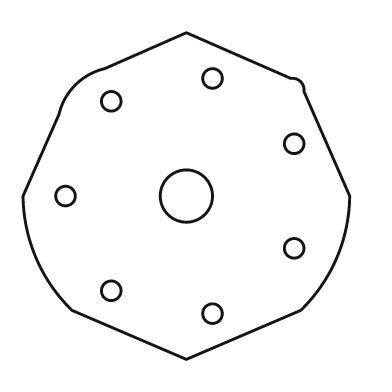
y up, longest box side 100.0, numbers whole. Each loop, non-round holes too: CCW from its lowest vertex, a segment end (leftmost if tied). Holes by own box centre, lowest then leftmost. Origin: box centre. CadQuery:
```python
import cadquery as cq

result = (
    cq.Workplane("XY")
    .moveTo(0.0, -50.0)
    .lineTo(35.0, -35.0)
    .threePointArc((46.0, -19.0), (50.0, 0.0))
    .lineTo(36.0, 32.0)
    .threePointArc((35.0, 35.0), (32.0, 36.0))
    .lineTo(0.0, 50.0)
    .lineTo(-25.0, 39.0)
    .threePointArc((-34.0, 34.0), (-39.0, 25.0))
    .lineTo(-50.0, 0.0)
    .threePointArc((-46.0, -19.0), (-35.0, -35.0))
    .close()
    .moveTo(8.0, -36.0)
    .circle(3.0)
    .moveTo(-23.0, -29.0)
    .circle(3.0)
    .moveTo(33.0, -16.0)
    .circle(3.0)
    .moveTo(-37.0, 0.0)
    .circle(3.0)
    .moveTo(0.0, 0.0)
    .circle(8.0)
    .moveTo(33.0, 16.0)
    .circle(3.0)
    .moveTo(-23.0, 29.0)
    .circle(3.0)
    .moveTo(8.0, 36.0)
    .circle(3.0)
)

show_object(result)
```